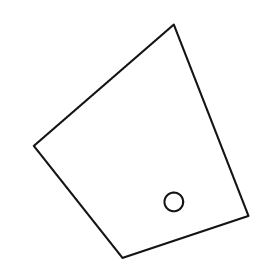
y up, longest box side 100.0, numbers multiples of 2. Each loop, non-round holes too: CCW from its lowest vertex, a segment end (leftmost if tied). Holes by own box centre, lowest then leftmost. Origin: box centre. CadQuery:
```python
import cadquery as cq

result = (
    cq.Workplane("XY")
    .moveTo(-8.0, -50.0)
    .lineTo(46.0, -32.0)
    .lineTo(14.0, 50.0)
    .lineTo(-46.0, -2.0)
    .close()
    .moveTo(14.0, -26.0)
    .circle(4.0)
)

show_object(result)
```